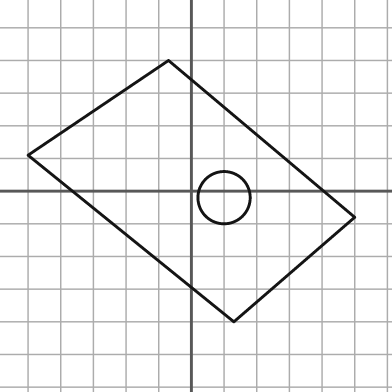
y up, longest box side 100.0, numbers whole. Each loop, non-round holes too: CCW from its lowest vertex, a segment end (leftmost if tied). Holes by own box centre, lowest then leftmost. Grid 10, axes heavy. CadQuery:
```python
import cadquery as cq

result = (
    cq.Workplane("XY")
    .moveTo(13.0, -40.0)
    .lineTo(50.0, -8.0)
    .lineTo(-7.0, 40.0)
    .lineTo(-50.0, 11.0)
    .close()
    .moveTo(10.0, -2.0)
    .circle(8.0)
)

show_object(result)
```